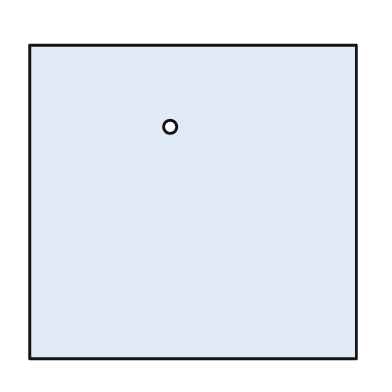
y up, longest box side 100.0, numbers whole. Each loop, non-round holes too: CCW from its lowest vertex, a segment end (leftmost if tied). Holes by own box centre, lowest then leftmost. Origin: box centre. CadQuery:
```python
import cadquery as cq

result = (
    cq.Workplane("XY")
    .moveTo(-50.0, -48.0)
    .lineTo(50.0, -48.0)
    .lineTo(50.0, 48.0)
    .lineTo(-50.0, 48.0)
    .close()
    .moveTo(-7.0, 23.0)
    .circle(2.0)
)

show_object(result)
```